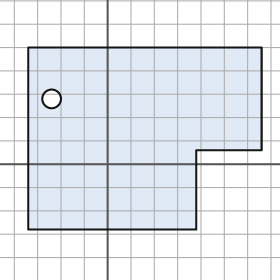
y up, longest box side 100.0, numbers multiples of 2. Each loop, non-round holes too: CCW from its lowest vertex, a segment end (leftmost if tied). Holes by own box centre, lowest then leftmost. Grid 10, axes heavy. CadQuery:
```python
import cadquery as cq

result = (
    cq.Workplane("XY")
    .moveTo(-34.0, -28.0)
    .lineTo(38.0, -28.0)
    .lineTo(38.0, 6.0)
    .lineTo(66.0, 6.0)
    .lineTo(66.0, 50.0)
    .lineTo(-34.0, 50.0)
    .close()
    .moveTo(-24.0, 28.0)
    .circle(4.0)
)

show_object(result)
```